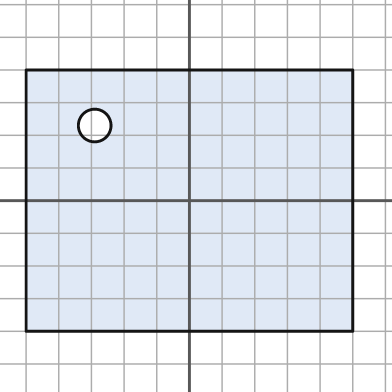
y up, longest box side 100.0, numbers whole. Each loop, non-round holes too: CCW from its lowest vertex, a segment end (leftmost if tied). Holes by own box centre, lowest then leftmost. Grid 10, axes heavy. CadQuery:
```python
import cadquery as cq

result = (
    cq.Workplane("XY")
    .moveTo(-50.0, -40.0)
    .lineTo(50.0, -40.0)
    .lineTo(50.0, 40.0)
    .lineTo(-50.0, 40.0)
    .close()
    .moveTo(-29.0, 23.0)
    .circle(5.0)
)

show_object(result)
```